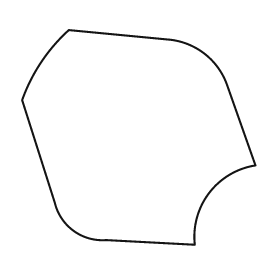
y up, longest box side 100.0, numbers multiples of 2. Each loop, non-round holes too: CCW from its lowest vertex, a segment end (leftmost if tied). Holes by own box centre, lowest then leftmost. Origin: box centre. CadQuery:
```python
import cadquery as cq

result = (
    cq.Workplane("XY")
    .moveTo(24.0, -46.0)
    .threePointArc((30.0, -24.0), (50.0, -12.0))
    .lineTo(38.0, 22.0)
    .threePointArc((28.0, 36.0), (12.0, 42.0))
    .lineTo(-30.0, 46.0)
    .threePointArc((-42.0, 32.0), (-50.0, 16.0))
    .lineTo(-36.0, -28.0)
    .threePointArc((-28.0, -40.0), (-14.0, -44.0))
    .close()
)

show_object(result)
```